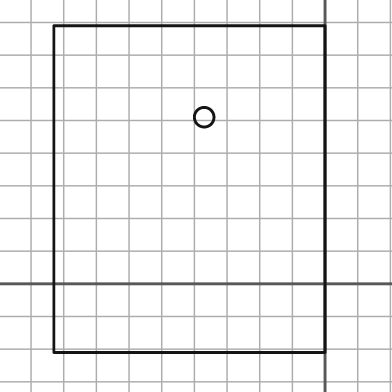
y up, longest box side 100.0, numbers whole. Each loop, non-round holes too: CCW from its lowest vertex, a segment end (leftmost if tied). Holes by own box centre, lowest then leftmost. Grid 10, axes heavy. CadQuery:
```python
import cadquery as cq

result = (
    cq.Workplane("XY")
    .moveTo(-83.0, -21.0)
    .lineTo(0.0, -21.0)
    .lineTo(0.0, 79.0)
    .lineTo(-83.0, 79.0)
    .close()
    .moveTo(-37.0, 51.0)
    .circle(3.0)
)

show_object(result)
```